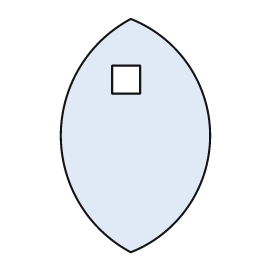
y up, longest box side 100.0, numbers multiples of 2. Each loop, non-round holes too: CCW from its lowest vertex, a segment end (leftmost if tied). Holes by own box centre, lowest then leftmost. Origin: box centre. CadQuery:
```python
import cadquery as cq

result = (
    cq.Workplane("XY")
    .moveTo(-2.0, -50.0)
    .threePointArc((32.0, 0.0), (-2.0, 50.0))
    .threePointArc((-32.0, 0.0), (-2.0, -50.0))
    .close()
    .moveTo(-10.0, 18.0)
    .lineTo(2.0, 18.0)
    .lineTo(2.0, 30.0)
    .lineTo(-10.0, 30.0)
    .close()
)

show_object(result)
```